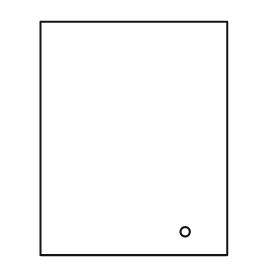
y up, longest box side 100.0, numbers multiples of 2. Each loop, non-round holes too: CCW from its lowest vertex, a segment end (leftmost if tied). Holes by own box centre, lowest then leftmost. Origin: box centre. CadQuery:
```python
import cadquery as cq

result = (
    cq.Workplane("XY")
    .moveTo(-40.0, -50.0)
    .lineTo(40.0, -50.0)
    .lineTo(40.0, 50.0)
    .lineTo(-40.0, 50.0)
    .close()
    .moveTo(22.0, -40.0)
    .circle(2.0)
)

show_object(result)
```